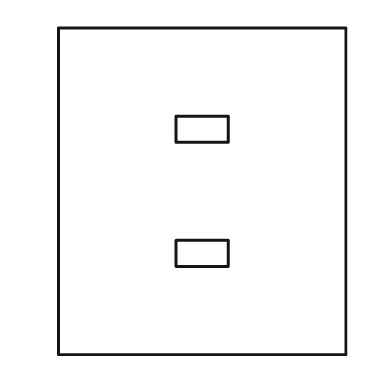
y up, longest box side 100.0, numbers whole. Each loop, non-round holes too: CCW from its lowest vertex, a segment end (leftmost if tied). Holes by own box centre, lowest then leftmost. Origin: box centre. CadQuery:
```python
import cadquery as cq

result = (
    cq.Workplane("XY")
    .moveTo(-44.0, -50.0)
    .lineTo(44.0, -50.0)
    .lineTo(44.0, 50.0)
    .lineTo(-44.0, 50.0)
    .close()
    .moveTo(-8.0, -23.0)
    .lineTo(8.0, -23.0)
    .lineTo(8.0, -15.0)
    .lineTo(-8.0, -15.0)
    .close()
    .moveTo(-8.0, 15.0)
    .lineTo(8.0, 15.0)
    .lineTo(8.0, 23.0)
    .lineTo(-8.0, 23.0)
    .close()
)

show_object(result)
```